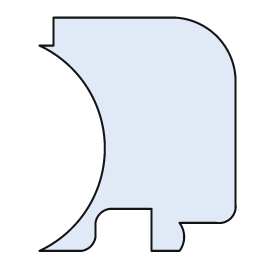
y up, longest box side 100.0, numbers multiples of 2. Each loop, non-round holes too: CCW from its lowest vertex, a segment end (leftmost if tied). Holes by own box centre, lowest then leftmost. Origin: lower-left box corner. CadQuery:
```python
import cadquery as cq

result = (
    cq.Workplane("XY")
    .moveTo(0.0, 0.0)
    .lineTo(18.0, 0.0)
    .threePointArc((22.0, 2.0), (24.0, 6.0))
    .lineTo(24.0, 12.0)
    .threePointArc((26.0, 16.0), (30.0, 18.0))
    .lineTo(48.0, 18.0)
    .lineTo(48.0, 0.0)
    .lineTo(60.0, 0.0)
    .threePointArc((62.0, 6.0), (60.0, 12.0))
    .lineTo(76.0, 12.0)
    .threePointArc((82.0, 14.0), (84.0, 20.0))
    .lineTo(84.0, 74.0)
    .threePointArc((76.0, 92.0), (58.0, 100.0))
    .lineTo(6.0, 100.0)
    .lineTo(6.0, 88.0)
    .lineTo(0.0, 88.0)
    .threePointArc((28.0, 44.0), (0.0, 0.0))
    .close()
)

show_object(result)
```